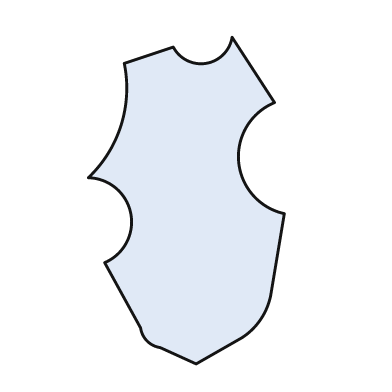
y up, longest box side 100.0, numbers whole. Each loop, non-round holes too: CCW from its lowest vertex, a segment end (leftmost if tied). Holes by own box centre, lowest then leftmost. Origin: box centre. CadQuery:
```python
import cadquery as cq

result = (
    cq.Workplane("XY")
    .moveTo(3.0, -50.0)
    .lineTo(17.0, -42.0)
    .threePointArc((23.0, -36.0), (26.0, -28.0))
    .lineTo(30.0, -4.0)
    .threePointArc((16.0, 12.0), (27.0, 30.0))
    .lineTo(14.0, 50.0)
    .threePointArc((6.0, 42.0), (-4.0, 47.0))
    .lineTo(-19.0, 42.0)
    .threePointArc((-20.0, 23.0), (-30.0, 7.0))
    .threePointArc((-17.0, -4.0), (-25.0, -19.0))
    .lineTo(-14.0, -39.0)
    .threePointArc((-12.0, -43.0), (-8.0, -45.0))
    .close()
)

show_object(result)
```